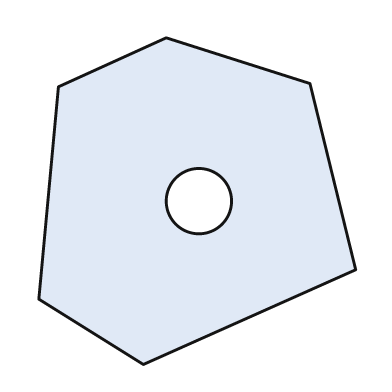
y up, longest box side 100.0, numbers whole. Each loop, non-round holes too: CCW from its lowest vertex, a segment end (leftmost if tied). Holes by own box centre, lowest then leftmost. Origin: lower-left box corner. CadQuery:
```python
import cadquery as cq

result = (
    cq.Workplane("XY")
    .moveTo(32.0, 0.0)
    .lineTo(97.0, 29.0)
    .lineTo(83.0, 86.0)
    .lineTo(39.0, 100.0)
    .lineTo(6.0, 85.0)
    .lineTo(0.0, 20.0)
    .close()
    .moveTo(49.0, 50.0)
    .circle(10.0)
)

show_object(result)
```